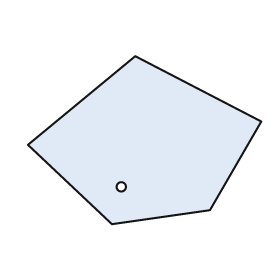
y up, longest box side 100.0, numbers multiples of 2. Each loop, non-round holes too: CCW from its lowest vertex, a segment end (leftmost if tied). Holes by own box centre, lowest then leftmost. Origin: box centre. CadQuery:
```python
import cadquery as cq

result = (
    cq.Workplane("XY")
    .moveTo(-14.0, -36.0)
    .lineTo(28.0, -30.0)
    .lineTo(50.0, 8.0)
    .lineTo(-4.0, 36.0)
    .lineTo(-50.0, -2.0)
    .close()
    .moveTo(-10.0, -20.0)
    .circle(2.0)
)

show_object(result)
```